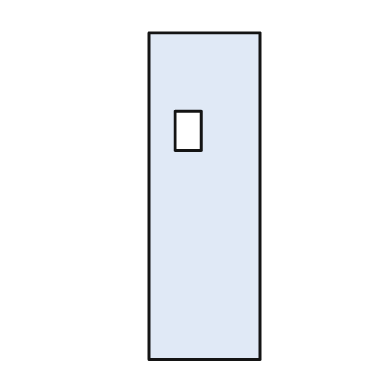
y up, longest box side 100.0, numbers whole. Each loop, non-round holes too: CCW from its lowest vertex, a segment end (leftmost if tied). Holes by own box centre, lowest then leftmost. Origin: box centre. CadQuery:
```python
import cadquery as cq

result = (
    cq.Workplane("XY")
    .moveTo(-17.0, -50.0)
    .lineTo(17.0, -50.0)
    .lineTo(17.0, 50.0)
    .lineTo(-17.0, 50.0)
    .close()
    .moveTo(-9.0, 14.0)
    .lineTo(-1.0, 14.0)
    .lineTo(-1.0, 26.0)
    .lineTo(-9.0, 26.0)
    .close()
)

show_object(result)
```